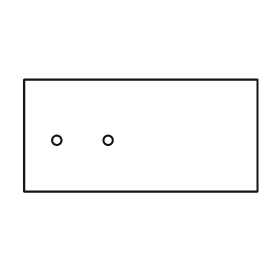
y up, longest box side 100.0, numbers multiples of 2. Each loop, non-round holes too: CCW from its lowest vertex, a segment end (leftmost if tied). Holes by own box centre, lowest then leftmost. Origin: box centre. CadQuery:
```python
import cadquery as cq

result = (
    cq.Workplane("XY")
    .moveTo(-50.0, -24.0)
    .lineTo(50.0, -24.0)
    .lineTo(50.0, 24.0)
    .lineTo(-50.0, 24.0)
    .close()
    .moveTo(-36.0, -2.0)
    .circle(2.0)
    .moveTo(-14.0, -2.0)
    .circle(2.0)
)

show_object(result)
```